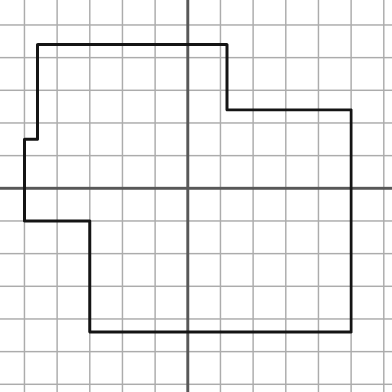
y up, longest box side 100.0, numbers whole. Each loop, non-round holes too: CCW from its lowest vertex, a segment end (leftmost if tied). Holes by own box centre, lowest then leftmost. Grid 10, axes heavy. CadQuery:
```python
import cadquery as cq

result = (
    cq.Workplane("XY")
    .moveTo(-30.0, -44.0)
    .lineTo(50.0, -44.0)
    .lineTo(50.0, 24.0)
    .lineTo(12.0, 24.0)
    .lineTo(12.0, 44.0)
    .lineTo(-46.0, 44.0)
    .lineTo(-46.0, 15.0)
    .lineTo(-50.0, 15.0)
    .lineTo(-50.0, -10.0)
    .lineTo(-30.0, -10.0)
    .close()
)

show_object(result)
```